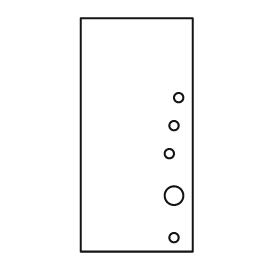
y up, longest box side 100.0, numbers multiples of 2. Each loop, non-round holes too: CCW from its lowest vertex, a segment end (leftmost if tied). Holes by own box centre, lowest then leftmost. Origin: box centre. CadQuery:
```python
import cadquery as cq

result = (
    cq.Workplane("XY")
    .moveTo(-24.0, -50.0)
    .lineTo(24.0, -50.0)
    .lineTo(24.0, 50.0)
    .lineTo(-24.0, 50.0)
    .close()
    .moveTo(16.0, -44.0)
    .circle(2.0)
    .moveTo(16.0, -26.0)
    .circle(4.0)
    .moveTo(14.0, -8.0)
    .circle(2.0)
    .moveTo(16.0, 4.0)
    .circle(2.0)
    .moveTo(18.0, 16.0)
    .circle(2.0)
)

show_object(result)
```